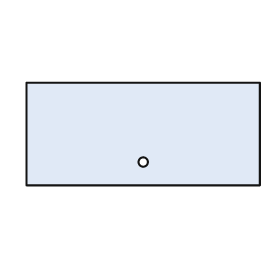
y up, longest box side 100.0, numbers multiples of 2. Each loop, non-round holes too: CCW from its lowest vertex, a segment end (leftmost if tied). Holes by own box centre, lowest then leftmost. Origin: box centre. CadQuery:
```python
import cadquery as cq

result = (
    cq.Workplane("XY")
    .moveTo(-50.0, -22.0)
    .lineTo(50.0, -22.0)
    .lineTo(50.0, 22.0)
    .lineTo(-50.0, 22.0)
    .close()
    .moveTo(0.0, -12.0)
    .circle(2.0)
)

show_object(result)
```